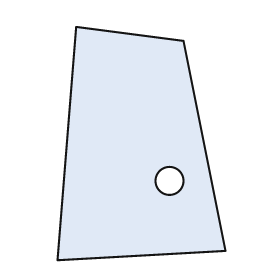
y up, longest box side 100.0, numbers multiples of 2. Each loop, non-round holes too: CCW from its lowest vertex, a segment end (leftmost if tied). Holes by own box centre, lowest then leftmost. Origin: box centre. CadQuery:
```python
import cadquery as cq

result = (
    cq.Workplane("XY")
    .moveTo(-36.0, -50.0)
    .lineTo(36.0, -46.0)
    .lineTo(18.0, 44.0)
    .lineTo(-28.0, 50.0)
    .close()
    .moveTo(12.0, -16.0)
    .circle(6.0)
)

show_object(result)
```